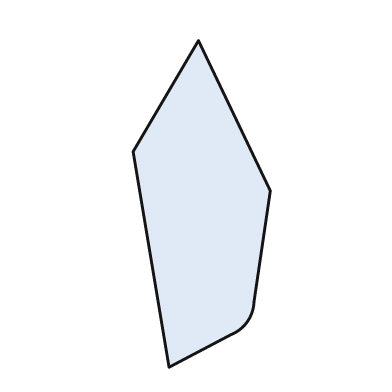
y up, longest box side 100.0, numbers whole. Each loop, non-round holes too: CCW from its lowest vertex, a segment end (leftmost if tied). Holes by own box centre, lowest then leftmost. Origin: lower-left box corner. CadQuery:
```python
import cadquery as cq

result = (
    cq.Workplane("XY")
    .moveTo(11.0, 0.0)
    .lineTo(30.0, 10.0)
    .threePointArc((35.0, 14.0), (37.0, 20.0))
    .lineTo(42.0, 54.0)
    .lineTo(20.0, 100.0)
    .lineTo(0.0, 66.0)
    .close()
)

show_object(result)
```